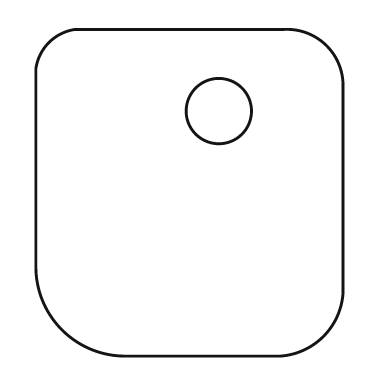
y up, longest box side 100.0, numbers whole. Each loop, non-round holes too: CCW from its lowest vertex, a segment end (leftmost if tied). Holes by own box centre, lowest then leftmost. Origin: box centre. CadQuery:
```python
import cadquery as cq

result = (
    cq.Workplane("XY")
    .moveTo(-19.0, -50.0)
    .lineTo(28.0, -50.0)
    .threePointArc((41.0, -44.0), (47.0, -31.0))
    .lineTo(47.0, 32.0)
    .threePointArc((42.0, 45.0), (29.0, 50.0))
    .lineTo(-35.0, 50.0)
    .threePointArc((-43.0, 46.0), (-47.0, 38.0))
    .lineTo(-47.0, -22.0)
    .threePointArc((-39.0, -42.0), (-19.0, -50.0))
    .close()
    .moveTo(9.0, 25.0)
    .circle(10.0)
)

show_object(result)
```